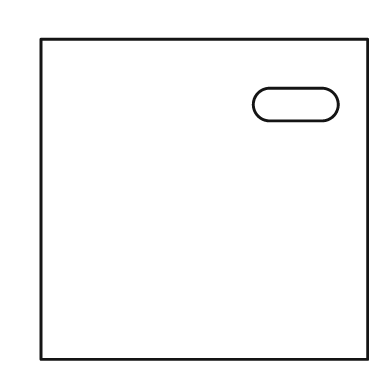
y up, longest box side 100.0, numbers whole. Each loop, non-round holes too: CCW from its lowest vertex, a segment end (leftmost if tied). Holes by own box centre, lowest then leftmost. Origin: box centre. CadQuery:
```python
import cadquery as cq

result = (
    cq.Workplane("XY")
    .moveTo(-50.0, -49.0)
    .lineTo(50.0, -49.0)
    .lineTo(50.0, 49.0)
    .lineTo(-50.0, 49.0)
    .close()
    .moveTo(20.0, 24.0)
    .lineTo(36.0, 24.0)
    .threePointArc((41.0, 29.0), (36.0, 34.0))
    .lineTo(20.0, 34.0)
    .threePointArc((15.0, 29.0), (20.0, 24.0))
    .close()
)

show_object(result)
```